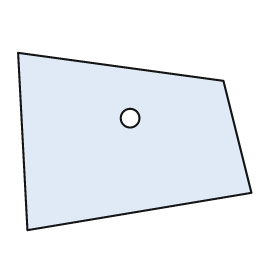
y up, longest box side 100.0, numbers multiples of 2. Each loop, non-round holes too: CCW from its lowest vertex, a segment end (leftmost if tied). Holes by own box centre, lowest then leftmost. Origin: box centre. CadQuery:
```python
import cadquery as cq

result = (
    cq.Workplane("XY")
    .moveTo(-46.0, -38.0)
    .lineTo(50.0, -22.0)
    .lineTo(38.0, 26.0)
    .lineTo(-50.0, 38.0)
    .close()
    .moveTo(-2.0, 10.0)
    .circle(4.0)
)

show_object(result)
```